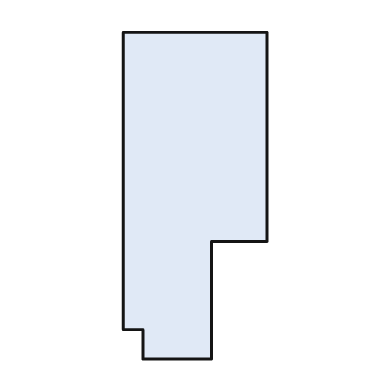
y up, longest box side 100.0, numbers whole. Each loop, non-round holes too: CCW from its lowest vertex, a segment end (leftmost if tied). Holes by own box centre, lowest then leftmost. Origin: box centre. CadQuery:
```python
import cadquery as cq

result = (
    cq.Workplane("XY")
    .moveTo(-16.0, -50.0)
    .lineTo(5.0, -50.0)
    .lineTo(5.0, -14.0)
    .lineTo(22.0, -14.0)
    .lineTo(22.0, 50.0)
    .lineTo(-22.0, 50.0)
    .lineTo(-22.0, -41.0)
    .lineTo(-16.0, -41.0)
    .close()
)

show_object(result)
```